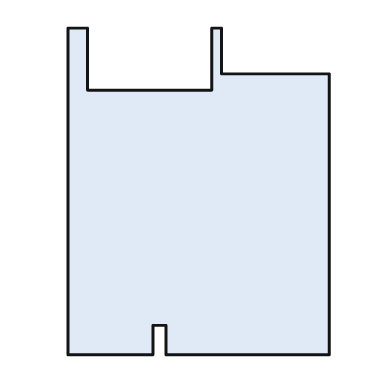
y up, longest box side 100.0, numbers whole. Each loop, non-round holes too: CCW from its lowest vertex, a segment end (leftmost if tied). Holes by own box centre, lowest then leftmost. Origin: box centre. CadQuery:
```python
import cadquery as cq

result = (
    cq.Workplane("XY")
    .moveTo(-40.0, -50.0)
    .lineTo(-14.0, -50.0)
    .lineTo(-14.0, -41.0)
    .lineTo(-10.0, -41.0)
    .lineTo(-10.0, -50.0)
    .lineTo(40.0, -50.0)
    .lineTo(40.0, 36.0)
    .lineTo(7.0, 36.0)
    .lineTo(7.0, 50.0)
    .lineTo(4.0, 50.0)
    .lineTo(4.0, 31.0)
    .lineTo(-34.0, 31.0)
    .lineTo(-34.0, 50.0)
    .lineTo(-40.0, 50.0)
    .close()
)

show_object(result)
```